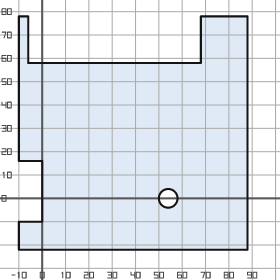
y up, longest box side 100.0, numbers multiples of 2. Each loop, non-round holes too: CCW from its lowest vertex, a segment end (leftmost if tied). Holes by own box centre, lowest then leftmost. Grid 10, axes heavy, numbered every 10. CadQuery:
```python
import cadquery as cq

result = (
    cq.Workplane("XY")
    .moveTo(-10.0, -22.0)
    .lineTo(88.0, -22.0)
    .lineTo(88.0, 78.0)
    .lineTo(68.0, 78.0)
    .lineTo(68.0, 58.0)
    .lineTo(-6.0, 58.0)
    .lineTo(-6.0, 78.0)
    .lineTo(-10.0, 78.0)
    .lineTo(-10.0, 16.0)
    .lineTo(0.0, 16.0)
    .lineTo(0.0, -10.0)
    .lineTo(-10.0, -10.0)
    .close()
    .moveTo(54.0, 0.0)
    .circle(4.0)
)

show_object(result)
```